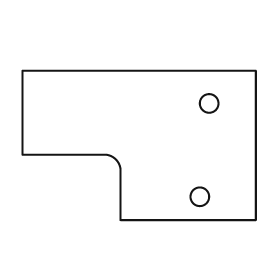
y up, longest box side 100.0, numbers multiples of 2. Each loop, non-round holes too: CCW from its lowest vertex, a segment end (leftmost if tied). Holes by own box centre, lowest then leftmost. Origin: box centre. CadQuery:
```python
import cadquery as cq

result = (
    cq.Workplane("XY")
    .moveTo(-8.0, -32.0)
    .lineTo(50.0, -32.0)
    .lineTo(50.0, 32.0)
    .lineTo(-50.0, 32.0)
    .lineTo(-50.0, -4.0)
    .lineTo(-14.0, -4.0)
    .threePointArc((-10.0, -6.0), (-8.0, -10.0))
    .close()
    .moveTo(26.0, -22.0)
    .circle(4.0)
    .moveTo(30.0, 18.0)
    .circle(4.0)
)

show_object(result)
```